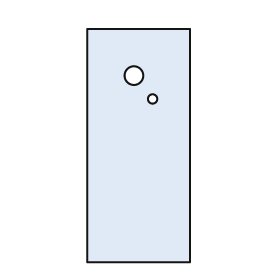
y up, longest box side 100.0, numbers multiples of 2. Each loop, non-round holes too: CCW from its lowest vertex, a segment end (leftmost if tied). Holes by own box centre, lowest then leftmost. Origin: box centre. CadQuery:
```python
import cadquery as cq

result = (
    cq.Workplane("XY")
    .moveTo(-22.0, -50.0)
    .lineTo(22.0, -50.0)
    .lineTo(22.0, 50.0)
    .lineTo(-22.0, 50.0)
    .close()
    .moveTo(6.0, 20.0)
    .circle(2.0)
    .moveTo(-2.0, 30.0)
    .circle(4.0)
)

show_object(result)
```